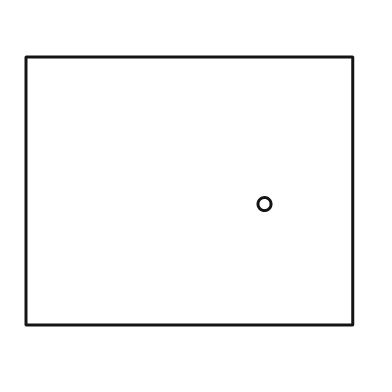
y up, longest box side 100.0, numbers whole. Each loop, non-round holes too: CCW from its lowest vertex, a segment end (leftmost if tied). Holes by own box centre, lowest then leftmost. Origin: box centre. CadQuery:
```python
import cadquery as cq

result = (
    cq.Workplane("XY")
    .moveTo(-50.0, -41.0)
    .lineTo(50.0, -41.0)
    .lineTo(50.0, 41.0)
    .lineTo(-50.0, 41.0)
    .close()
    .moveTo(23.0, -4.0)
    .circle(2.0)
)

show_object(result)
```